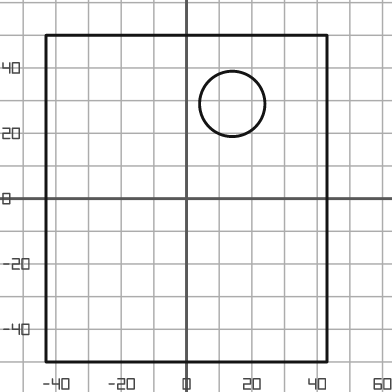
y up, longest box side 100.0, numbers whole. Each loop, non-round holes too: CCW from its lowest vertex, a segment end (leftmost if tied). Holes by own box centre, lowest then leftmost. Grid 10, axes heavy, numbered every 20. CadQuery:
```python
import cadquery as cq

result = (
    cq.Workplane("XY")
    .moveTo(-43.0, -50.0)
    .lineTo(43.0, -50.0)
    .lineTo(43.0, 50.0)
    .lineTo(-43.0, 50.0)
    .close()
    .moveTo(14.0, 29.0)
    .circle(10.0)
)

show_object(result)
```